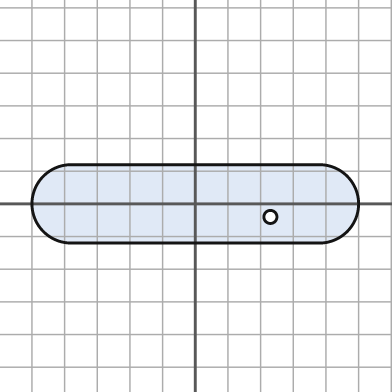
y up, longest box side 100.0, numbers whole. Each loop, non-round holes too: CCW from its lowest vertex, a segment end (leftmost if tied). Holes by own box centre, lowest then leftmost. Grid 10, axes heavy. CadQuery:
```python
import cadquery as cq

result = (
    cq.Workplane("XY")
    .moveTo(-38.0, -12.0)
    .lineTo(38.0, -12.0)
    .threePointArc((50.0, 0.0), (38.0, 12.0))
    .lineTo(-38.0, 12.0)
    .threePointArc((-50.0, 0.0), (-38.0, -12.0))
    .close()
    .moveTo(23.0, -4.0)
    .circle(2.0)
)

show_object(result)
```